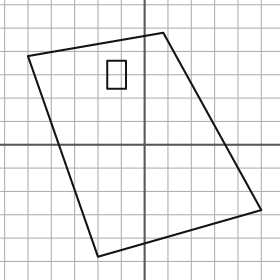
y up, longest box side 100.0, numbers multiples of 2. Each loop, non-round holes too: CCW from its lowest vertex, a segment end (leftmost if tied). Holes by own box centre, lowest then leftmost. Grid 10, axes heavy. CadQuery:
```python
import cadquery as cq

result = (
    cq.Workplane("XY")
    .moveTo(-20.0, -48.0)
    .lineTo(50.0, -28.0)
    .lineTo(8.0, 48.0)
    .lineTo(-50.0, 38.0)
    .close()
    .moveTo(-16.0, 24.0)
    .lineTo(-8.0, 24.0)
    .lineTo(-8.0, 36.0)
    .lineTo(-16.0, 36.0)
    .close()
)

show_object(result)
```